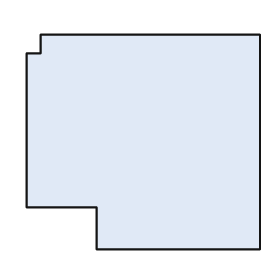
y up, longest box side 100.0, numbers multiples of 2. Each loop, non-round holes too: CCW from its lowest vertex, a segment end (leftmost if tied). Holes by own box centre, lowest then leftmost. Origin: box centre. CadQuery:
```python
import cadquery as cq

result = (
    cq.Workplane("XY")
    .moveTo(-20.0, -46.0)
    .lineTo(50.0, -46.0)
    .lineTo(50.0, 46.0)
    .lineTo(-44.0, 46.0)
    .lineTo(-44.0, 38.0)
    .lineTo(-50.0, 38.0)
    .lineTo(-50.0, -28.0)
    .lineTo(-20.0, -28.0)
    .close()
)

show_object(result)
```